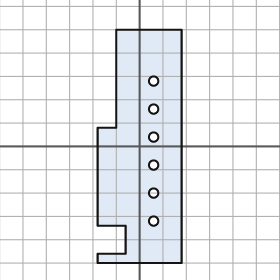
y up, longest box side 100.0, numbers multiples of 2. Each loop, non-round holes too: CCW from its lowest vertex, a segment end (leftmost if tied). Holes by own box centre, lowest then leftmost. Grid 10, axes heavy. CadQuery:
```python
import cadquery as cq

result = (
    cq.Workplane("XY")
    .moveTo(-18.0, -50.0)
    .lineTo(18.0, -50.0)
    .lineTo(18.0, 50.0)
    .lineTo(-10.0, 50.0)
    .lineTo(-10.0, 8.0)
    .lineTo(-18.0, 8.0)
    .lineTo(-18.0, -34.0)
    .lineTo(-6.0, -34.0)
    .lineTo(-6.0, -46.0)
    .lineTo(-18.0, -46.0)
    .close()
    .moveTo(6.0, -32.0)
    .circle(2.0)
    .moveTo(6.0, -20.0)
    .circle(2.0)
    .moveTo(6.0, -8.0)
    .circle(2.0)
    .moveTo(6.0, 4.0)
    .circle(2.0)
    .moveTo(6.0, 16.0)
    .circle(2.0)
    .moveTo(6.0, 28.0)
    .circle(2.0)
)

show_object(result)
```